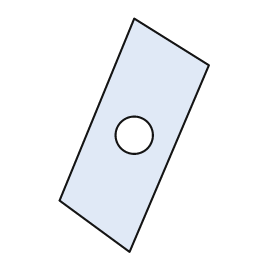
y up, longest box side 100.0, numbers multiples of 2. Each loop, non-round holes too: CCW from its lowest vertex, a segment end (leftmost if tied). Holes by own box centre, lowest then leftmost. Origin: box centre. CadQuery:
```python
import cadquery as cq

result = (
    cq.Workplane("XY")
    .moveTo(-2.0, -50.0)
    .lineTo(32.0, 30.0)
    .lineTo(0.0, 50.0)
    .lineTo(-32.0, -28.0)
    .close()
    .moveTo(0.0, 0.0)
    .circle(8.0)
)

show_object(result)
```